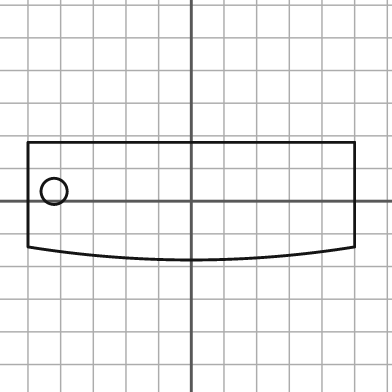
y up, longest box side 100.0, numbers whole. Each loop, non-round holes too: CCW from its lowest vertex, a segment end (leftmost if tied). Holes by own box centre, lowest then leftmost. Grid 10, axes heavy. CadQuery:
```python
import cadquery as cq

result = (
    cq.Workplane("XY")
    .moveTo(-50.0, -14.0)
    .threePointArc((0.0, -18.0), (50.0, -14.0))
    .lineTo(50.0, 18.0)
    .lineTo(-50.0, 18.0)
    .close()
    .moveTo(-42.0, 3.0)
    .circle(4.0)
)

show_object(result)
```